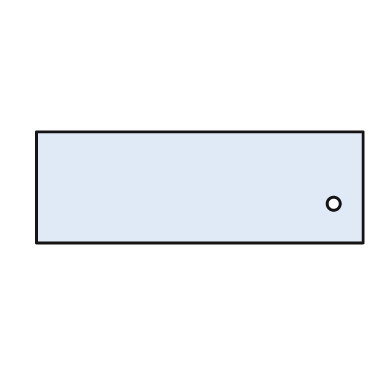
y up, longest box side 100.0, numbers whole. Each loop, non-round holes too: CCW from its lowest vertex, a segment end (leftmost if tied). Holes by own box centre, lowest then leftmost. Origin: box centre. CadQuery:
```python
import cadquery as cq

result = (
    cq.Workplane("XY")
    .moveTo(-50.0, -17.0)
    .lineTo(50.0, -17.0)
    .lineTo(50.0, 17.0)
    .lineTo(-50.0, 17.0)
    .close()
    .moveTo(41.0, -5.0)
    .circle(2.0)
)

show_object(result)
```